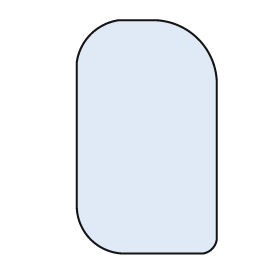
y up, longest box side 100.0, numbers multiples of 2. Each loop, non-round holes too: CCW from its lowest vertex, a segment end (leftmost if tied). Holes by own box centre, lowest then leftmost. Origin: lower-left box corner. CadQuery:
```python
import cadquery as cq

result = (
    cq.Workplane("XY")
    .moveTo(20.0, 0.0)
    .lineTo(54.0, 0.0)
    .threePointArc((58.0, 2.0), (60.0, 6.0))
    .lineTo(60.0, 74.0)
    .threePointArc((52.0, 92.0), (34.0, 100.0))
    .lineTo(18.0, 100.0)
    .threePointArc((6.0, 94.0), (0.0, 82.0))
    .lineTo(0.0, 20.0)
    .threePointArc((6.0, 6.0), (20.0, 0.0))
    .close()
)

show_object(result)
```